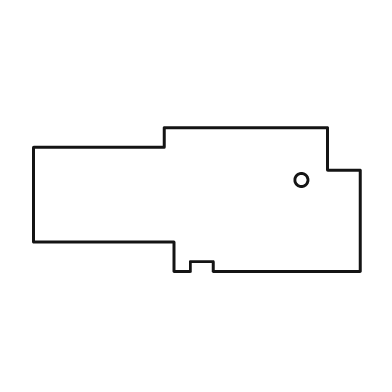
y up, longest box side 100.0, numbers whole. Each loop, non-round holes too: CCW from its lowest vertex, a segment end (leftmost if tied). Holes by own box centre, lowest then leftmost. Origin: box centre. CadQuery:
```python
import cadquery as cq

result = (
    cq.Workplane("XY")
    .moveTo(-7.0, -22.0)
    .lineTo(-2.0, -22.0)
    .lineTo(-2.0, -19.0)
    .lineTo(5.0, -19.0)
    .lineTo(5.0, -22.0)
    .lineTo(50.0, -22.0)
    .lineTo(50.0, 9.0)
    .lineTo(40.0, 9.0)
    .lineTo(40.0, 22.0)
    .lineTo(-10.0, 22.0)
    .lineTo(-10.0, 16.0)
    .lineTo(-50.0, 16.0)
    .lineTo(-50.0, -13.0)
    .lineTo(-7.0, -13.0)
    .close()
    .moveTo(32.0, 6.0)
    .circle(2.0)
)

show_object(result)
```